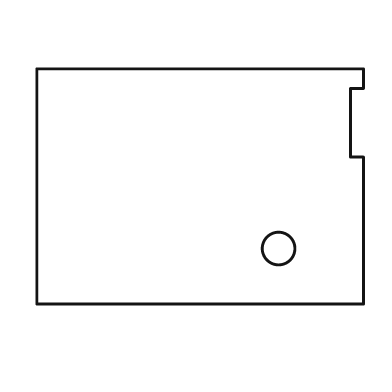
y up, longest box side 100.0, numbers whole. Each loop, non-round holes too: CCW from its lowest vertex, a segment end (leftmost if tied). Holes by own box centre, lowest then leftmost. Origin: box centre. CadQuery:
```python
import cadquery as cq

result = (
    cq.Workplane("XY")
    .moveTo(-50.0, -36.0)
    .lineTo(50.0, -36.0)
    .lineTo(50.0, 9.0)
    .lineTo(46.0, 9.0)
    .lineTo(46.0, 30.0)
    .lineTo(50.0, 30.0)
    .lineTo(50.0, 36.0)
    .lineTo(-50.0, 36.0)
    .close()
    .moveTo(24.0, -19.0)
    .circle(5.0)
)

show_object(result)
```